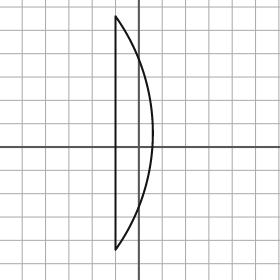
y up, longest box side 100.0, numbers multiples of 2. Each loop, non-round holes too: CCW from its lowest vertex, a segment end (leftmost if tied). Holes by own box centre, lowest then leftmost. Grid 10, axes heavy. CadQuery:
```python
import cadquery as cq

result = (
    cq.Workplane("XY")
    .moveTo(-10.0, -44.0)
    .threePointArc((6.0, 6.0), (-10.0, 56.0))
    .close()
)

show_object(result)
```